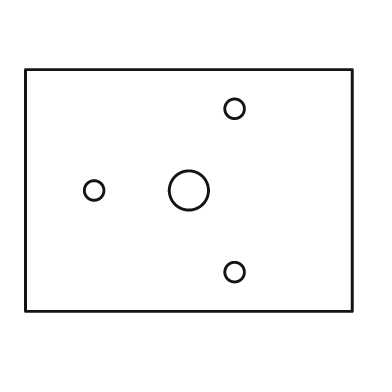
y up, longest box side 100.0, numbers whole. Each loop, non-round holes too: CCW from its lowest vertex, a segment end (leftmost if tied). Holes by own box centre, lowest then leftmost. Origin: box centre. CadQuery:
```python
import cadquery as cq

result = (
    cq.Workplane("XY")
    .moveTo(-50.0, -37.0)
    .lineTo(50.0, -37.0)
    .lineTo(50.0, 37.0)
    .lineTo(-50.0, 37.0)
    .close()
    .moveTo(14.0, -25.0)
    .circle(3.0)
    .moveTo(-29.0, 0.0)
    .circle(3.0)
    .moveTo(0.0, 0.0)
    .circle(6.0)
    .moveTo(14.0, 25.0)
    .circle(3.0)
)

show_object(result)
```